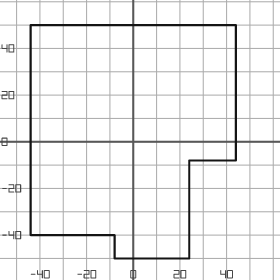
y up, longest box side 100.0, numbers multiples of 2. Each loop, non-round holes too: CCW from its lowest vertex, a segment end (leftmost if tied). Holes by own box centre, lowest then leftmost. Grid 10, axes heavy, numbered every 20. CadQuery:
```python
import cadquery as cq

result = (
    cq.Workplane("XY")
    .moveTo(-8.0, -50.0)
    .lineTo(24.0, -50.0)
    .lineTo(24.0, -8.0)
    .lineTo(44.0, -8.0)
    .lineTo(44.0, 50.0)
    .lineTo(-44.0, 50.0)
    .lineTo(-44.0, -40.0)
    .lineTo(-8.0, -40.0)
    .close()
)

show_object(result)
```